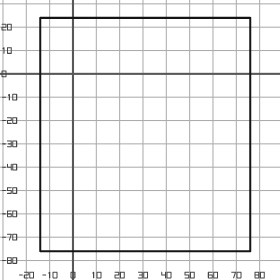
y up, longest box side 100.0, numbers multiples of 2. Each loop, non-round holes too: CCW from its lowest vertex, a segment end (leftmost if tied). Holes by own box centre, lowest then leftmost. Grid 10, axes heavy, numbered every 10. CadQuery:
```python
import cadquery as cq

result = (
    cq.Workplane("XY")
    .moveTo(-14.0, -76.0)
    .lineTo(76.0, -76.0)
    .lineTo(76.0, 24.0)
    .lineTo(-14.0, 24.0)
    .close()
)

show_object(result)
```